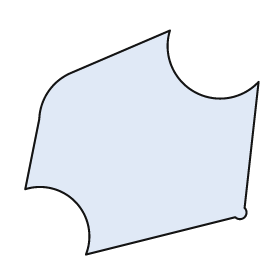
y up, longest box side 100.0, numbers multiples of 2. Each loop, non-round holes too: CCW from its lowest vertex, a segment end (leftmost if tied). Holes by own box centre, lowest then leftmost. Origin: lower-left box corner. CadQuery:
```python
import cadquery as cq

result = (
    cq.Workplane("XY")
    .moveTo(26.0, 0.0)
    .lineTo(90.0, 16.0)
    .threePointArc((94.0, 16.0), (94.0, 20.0))
    .lineTo(100.0, 74.0)
    .threePointArc((72.0, 70.0), (62.0, 96.0))
    .lineTo(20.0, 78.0)
    .threePointArc((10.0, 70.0), (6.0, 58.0))
    .lineTo(0.0, 28.0)
    .threePointArc((22.0, 22.0), (26.0, 0.0))
    .close()
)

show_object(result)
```